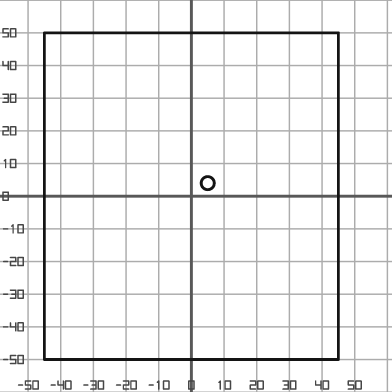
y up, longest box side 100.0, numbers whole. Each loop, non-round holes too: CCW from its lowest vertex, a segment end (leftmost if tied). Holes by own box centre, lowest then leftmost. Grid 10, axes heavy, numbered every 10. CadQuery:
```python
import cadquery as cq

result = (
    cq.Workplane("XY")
    .moveTo(-45.0, -50.0)
    .lineTo(45.0, -50.0)
    .lineTo(45.0, 50.0)
    .lineTo(-45.0, 50.0)
    .close()
    .moveTo(5.0, 4.0)
    .circle(2.0)
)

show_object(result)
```